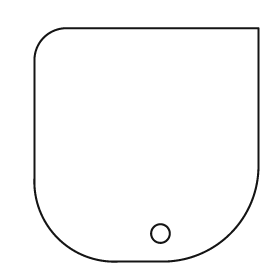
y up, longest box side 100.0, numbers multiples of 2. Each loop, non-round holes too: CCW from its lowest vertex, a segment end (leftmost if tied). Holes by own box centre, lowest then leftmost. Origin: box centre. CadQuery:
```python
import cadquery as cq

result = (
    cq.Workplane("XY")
    .moveTo(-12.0, -50.0)
    .lineTo(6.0, -50.0)
    .threePointArc((36.0, -38.0), (48.0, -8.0))
    .lineTo(48.0, 50.0)
    .lineTo(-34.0, 50.0)
    .threePointArc((-44.0, 46.0), (-48.0, 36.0))
    .lineTo(-48.0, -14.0)
    .threePointArc((-38.0, -40.0), (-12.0, -50.0))
    .close()
    .moveTo(6.0, -38.0)
    .circle(4.0)
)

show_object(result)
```